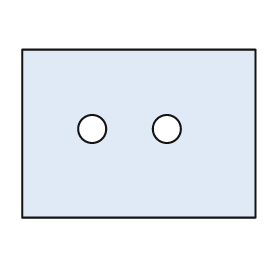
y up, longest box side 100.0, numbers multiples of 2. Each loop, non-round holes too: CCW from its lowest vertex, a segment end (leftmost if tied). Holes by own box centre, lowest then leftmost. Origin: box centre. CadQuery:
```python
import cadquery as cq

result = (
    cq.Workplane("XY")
    .moveTo(-50.0, -36.0)
    .lineTo(50.0, -36.0)
    .lineTo(50.0, 36.0)
    .lineTo(-50.0, 36.0)
    .close()
    .moveTo(-20.0, 2.0)
    .circle(6.0)
    .moveTo(12.0, 2.0)
    .circle(6.0)
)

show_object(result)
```